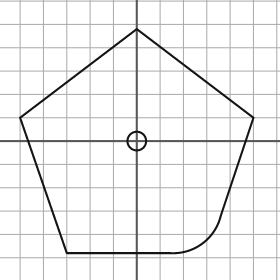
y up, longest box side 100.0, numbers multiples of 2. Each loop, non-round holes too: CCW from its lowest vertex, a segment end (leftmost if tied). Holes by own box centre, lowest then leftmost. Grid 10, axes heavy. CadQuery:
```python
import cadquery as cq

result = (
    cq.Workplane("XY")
    .moveTo(-30.0, -48.0)
    .lineTo(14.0, -48.0)
    .threePointArc((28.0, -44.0), (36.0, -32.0))
    .lineTo(50.0, 10.0)
    .lineTo(0.0, 48.0)
    .lineTo(-50.0, 10.0)
    .close()
    .moveTo(0.0, 0.0)
    .circle(4.0)
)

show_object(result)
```